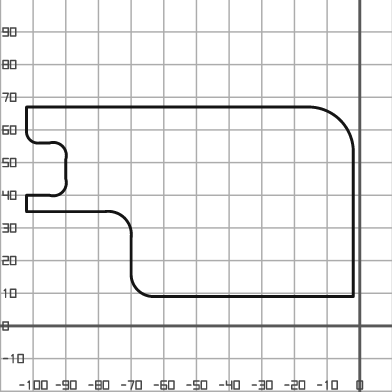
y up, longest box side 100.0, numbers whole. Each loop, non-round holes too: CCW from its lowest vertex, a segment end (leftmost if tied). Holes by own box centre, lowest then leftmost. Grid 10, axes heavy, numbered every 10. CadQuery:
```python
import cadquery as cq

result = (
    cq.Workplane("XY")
    .moveTo(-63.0, 9.0)
    .lineTo(-2.0, 9.0)
    .lineTo(-2.0, 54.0)
    .threePointArc((-6.0, 63.0), (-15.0, 67.0))
    .lineTo(-102.0, 67.0)
    .lineTo(-102.0, 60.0)
    .threePointArc((-101.0, 57.0), (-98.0, 56.0))
    .lineTo(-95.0, 56.0)
    .threePointArc((-91.0, 55.0), (-90.0, 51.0))
    .lineTo(-90.0, 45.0)
    .threePointArc((-91.0, 41.0), (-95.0, 40.0))
    .lineTo(-102.0, 40.0)
    .lineTo(-102.0, 35.0)
    .lineTo(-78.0, 35.0)
    .threePointArc((-72.0, 33.0), (-70.0, 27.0))
    .lineTo(-70.0, 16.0)
    .threePointArc((-68.0, 11.0), (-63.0, 9.0))
    .close()
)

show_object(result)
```